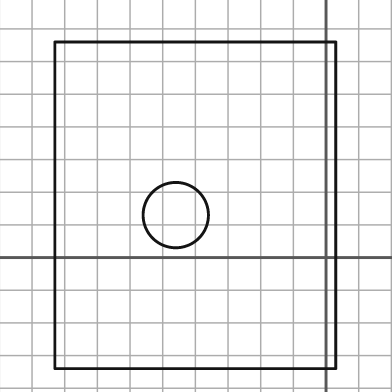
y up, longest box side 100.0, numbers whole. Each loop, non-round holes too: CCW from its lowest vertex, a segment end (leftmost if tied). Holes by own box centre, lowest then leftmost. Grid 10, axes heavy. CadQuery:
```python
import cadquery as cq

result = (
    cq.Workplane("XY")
    .moveTo(-83.0, -34.0)
    .lineTo(3.0, -34.0)
    .lineTo(3.0, 66.0)
    .lineTo(-83.0, 66.0)
    .close()
    .moveTo(-46.0, 13.0)
    .circle(10.0)
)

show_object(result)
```